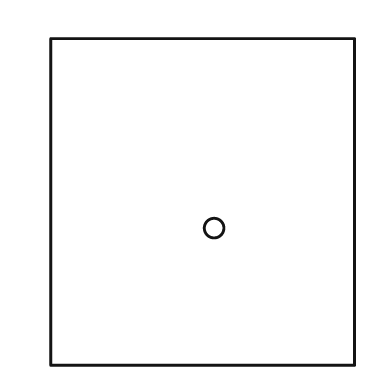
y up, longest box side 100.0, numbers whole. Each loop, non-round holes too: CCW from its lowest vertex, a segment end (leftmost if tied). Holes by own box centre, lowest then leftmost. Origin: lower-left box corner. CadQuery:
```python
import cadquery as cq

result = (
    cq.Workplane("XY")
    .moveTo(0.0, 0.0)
    .lineTo(93.0, 0.0)
    .lineTo(93.0, 100.0)
    .lineTo(0.0, 100.0)
    .close()
    .moveTo(50.0, 42.0)
    .circle(3.0)
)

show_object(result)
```